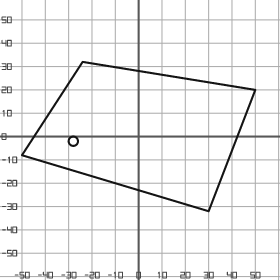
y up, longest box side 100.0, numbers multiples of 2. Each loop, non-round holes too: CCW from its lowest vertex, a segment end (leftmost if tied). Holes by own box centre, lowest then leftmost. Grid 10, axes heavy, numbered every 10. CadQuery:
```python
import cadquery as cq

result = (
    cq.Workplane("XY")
    .moveTo(30.0, -32.0)
    .lineTo(50.0, 20.0)
    .lineTo(-24.0, 32.0)
    .lineTo(-50.0, -8.0)
    .close()
    .moveTo(-28.0, -2.0)
    .circle(2.0)
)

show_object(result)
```